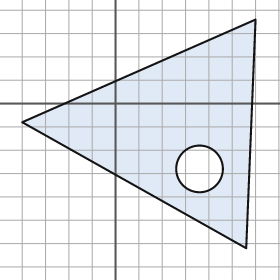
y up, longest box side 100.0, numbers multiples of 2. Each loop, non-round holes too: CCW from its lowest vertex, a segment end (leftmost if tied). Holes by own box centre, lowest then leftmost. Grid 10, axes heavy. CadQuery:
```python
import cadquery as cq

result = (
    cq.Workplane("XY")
    .moveTo(56.0, -62.0)
    .lineTo(60.0, 36.0)
    .lineTo(-40.0, -8.0)
    .close()
    .moveTo(36.0, -28.0)
    .circle(10.0)
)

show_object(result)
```